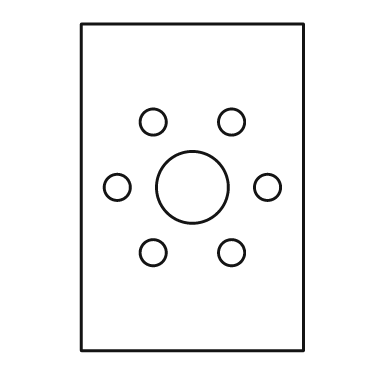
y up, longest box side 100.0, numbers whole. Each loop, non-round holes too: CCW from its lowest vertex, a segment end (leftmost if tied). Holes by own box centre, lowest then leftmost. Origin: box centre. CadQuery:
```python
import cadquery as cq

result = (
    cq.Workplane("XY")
    .moveTo(-34.0, -50.0)
    .lineTo(34.0, -50.0)
    .lineTo(34.0, 50.0)
    .lineTo(-34.0, 50.0)
    .close()
    .moveTo(-12.0, -20.0)
    .circle(4.0)
    .moveTo(12.0, -20.0)
    .circle(4.0)
    .moveTo(-23.0, 0.0)
    .circle(4.0)
    .moveTo(0.0, 0.0)
    .circle(11.0)
    .moveTo(23.0, 0.0)
    .circle(4.0)
    .moveTo(-12.0, 20.0)
    .circle(4.0)
    .moveTo(12.0, 20.0)
    .circle(4.0)
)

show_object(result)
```